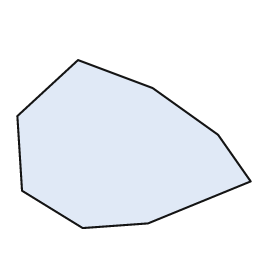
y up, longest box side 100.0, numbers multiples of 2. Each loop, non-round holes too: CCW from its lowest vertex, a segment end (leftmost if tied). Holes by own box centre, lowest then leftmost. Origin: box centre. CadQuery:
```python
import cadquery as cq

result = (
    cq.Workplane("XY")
    .moveTo(-22.0, -36.0)
    .lineTo(6.0, -34.0)
    .lineTo(50.0, -16.0)
    .lineTo(36.0, 4.0)
    .lineTo(8.0, 24.0)
    .lineTo(-24.0, 36.0)
    .lineTo(-50.0, 12.0)
    .lineTo(-48.0, -20.0)
    .close()
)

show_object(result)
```